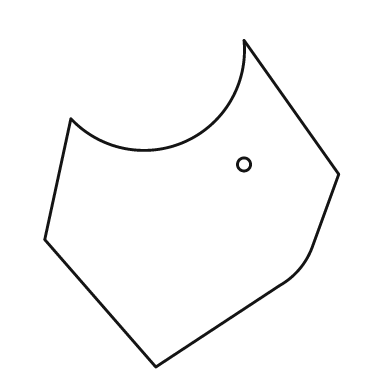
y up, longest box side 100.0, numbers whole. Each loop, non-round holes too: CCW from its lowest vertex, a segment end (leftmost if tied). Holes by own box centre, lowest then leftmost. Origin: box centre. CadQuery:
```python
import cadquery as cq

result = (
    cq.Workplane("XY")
    .moveTo(-11.0, -50.0)
    .lineTo(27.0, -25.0)
    .threePointArc((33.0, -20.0), (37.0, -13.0))
    .lineTo(45.0, 9.0)
    .lineTo(16.0, 50.0)
    .threePointArc((-2.0, 19.0), (-37.0, 26.0))
    .lineTo(-45.0, -11.0)
    .close()
    .moveTo(16.0, 12.0)
    .circle(2.0)
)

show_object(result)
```